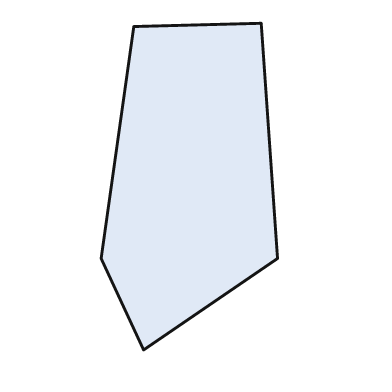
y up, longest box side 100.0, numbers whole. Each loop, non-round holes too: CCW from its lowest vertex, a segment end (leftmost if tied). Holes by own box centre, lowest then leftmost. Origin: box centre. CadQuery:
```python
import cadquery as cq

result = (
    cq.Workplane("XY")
    .moveTo(-14.0, -50.0)
    .lineTo(27.0, -22.0)
    .lineTo(22.0, 50.0)
    .lineTo(-17.0, 49.0)
    .lineTo(-27.0, -22.0)
    .close()
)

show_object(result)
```